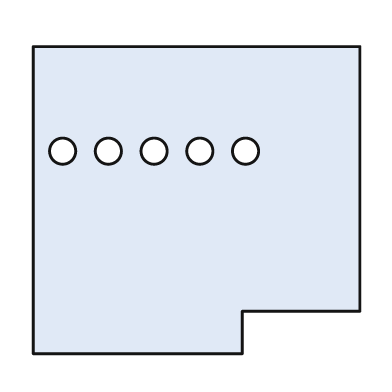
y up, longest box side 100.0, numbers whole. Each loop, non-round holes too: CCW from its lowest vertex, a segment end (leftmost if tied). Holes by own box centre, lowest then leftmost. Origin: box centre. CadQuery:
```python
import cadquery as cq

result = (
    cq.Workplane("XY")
    .moveTo(-50.0, -47.0)
    .lineTo(14.0, -47.0)
    .lineTo(14.0, -34.0)
    .lineTo(50.0, -34.0)
    .lineTo(50.0, 47.0)
    .lineTo(-50.0, 47.0)
    .close()
    .moveTo(-41.0, 15.0)
    .circle(4.0)
    .moveTo(-27.0, 15.0)
    .circle(4.0)
    .moveTo(-13.0, 15.0)
    .circle(4.0)
    .moveTo(1.0, 15.0)
    .circle(4.0)
    .moveTo(15.0, 15.0)
    .circle(4.0)
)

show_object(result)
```